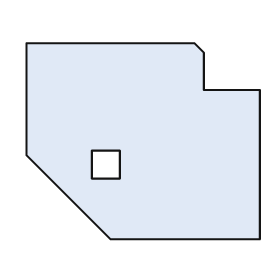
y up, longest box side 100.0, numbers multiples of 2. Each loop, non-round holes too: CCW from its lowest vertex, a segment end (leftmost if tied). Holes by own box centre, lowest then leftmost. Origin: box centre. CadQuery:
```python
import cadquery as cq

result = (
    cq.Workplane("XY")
    .moveTo(-14.0, -42.0)
    .lineTo(50.0, -42.0)
    .lineTo(50.0, 22.0)
    .lineTo(26.0, 22.0)
    .lineTo(26.0, 38.0)
    .lineTo(22.0, 42.0)
    .lineTo(-50.0, 42.0)
    .lineTo(-50.0, -6.0)
    .close()
    .moveTo(-22.0, -16.0)
    .lineTo(-10.0, -16.0)
    .lineTo(-10.0, -4.0)
    .lineTo(-22.0, -4.0)
    .close()
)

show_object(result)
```